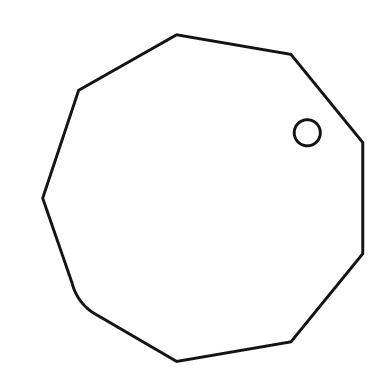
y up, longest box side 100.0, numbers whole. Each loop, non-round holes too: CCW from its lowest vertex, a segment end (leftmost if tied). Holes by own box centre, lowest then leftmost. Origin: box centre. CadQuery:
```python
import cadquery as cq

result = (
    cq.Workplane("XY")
    .moveTo(-8.0, -50.0)
    .lineTo(27.0, -44.0)
    .lineTo(49.0, -17.0)
    .lineTo(49.0, 17.0)
    .lineTo(27.0, 44.0)
    .lineTo(-8.0, 50.0)
    .lineTo(-38.0, 33.0)
    .lineTo(-49.0, 0.0)
    .lineTo(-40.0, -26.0)
    .threePointArc((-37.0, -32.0), (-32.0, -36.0))
    .close()
    .moveTo(32.0, 20.0)
    .circle(4.0)
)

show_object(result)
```